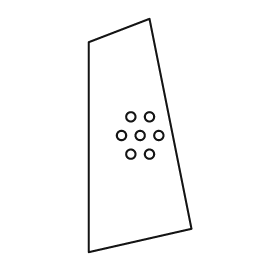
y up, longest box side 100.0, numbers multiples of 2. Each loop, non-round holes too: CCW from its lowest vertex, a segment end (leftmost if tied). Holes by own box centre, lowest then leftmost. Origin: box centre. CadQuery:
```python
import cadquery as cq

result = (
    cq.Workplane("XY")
    .moveTo(-22.0, -50.0)
    .lineTo(22.0, -40.0)
    .lineTo(4.0, 50.0)
    .lineTo(-22.0, 40.0)
    .close()
    .moveTo(-4.0, -8.0)
    .circle(2.0)
    .moveTo(4.0, -8.0)
    .circle(2.0)
    .moveTo(-8.0, 0.0)
    .circle(2.0)
    .moveTo(0.0, 0.0)
    .circle(2.0)
    .moveTo(8.0, 0.0)
    .circle(2.0)
    .moveTo(-4.0, 8.0)
    .circle(2.0)
    .moveTo(4.0, 8.0)
    .circle(2.0)
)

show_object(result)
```